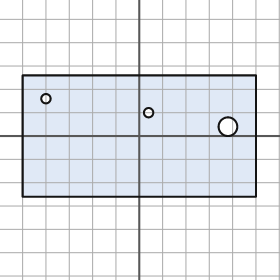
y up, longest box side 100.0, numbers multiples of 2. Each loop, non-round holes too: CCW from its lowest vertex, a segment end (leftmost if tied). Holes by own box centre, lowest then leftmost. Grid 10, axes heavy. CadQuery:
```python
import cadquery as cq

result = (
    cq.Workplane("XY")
    .moveTo(-50.0, -26.0)
    .lineTo(50.0, -26.0)
    .lineTo(50.0, 26.0)
    .lineTo(-50.0, 26.0)
    .close()
    .moveTo(38.0, 4.0)
    .circle(4.0)
    .moveTo(4.0, 10.0)
    .circle(2.0)
    .moveTo(-40.0, 16.0)
    .circle(2.0)
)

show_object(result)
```